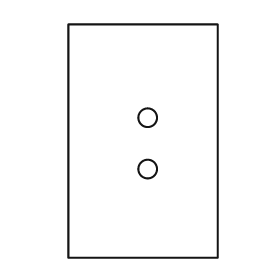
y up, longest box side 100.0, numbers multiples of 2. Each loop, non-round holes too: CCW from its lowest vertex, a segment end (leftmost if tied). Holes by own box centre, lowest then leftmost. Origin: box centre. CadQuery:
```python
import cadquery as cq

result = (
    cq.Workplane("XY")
    .moveTo(-32.0, -50.0)
    .lineTo(32.0, -50.0)
    .lineTo(32.0, 50.0)
    .lineTo(-32.0, 50.0)
    .close()
    .moveTo(2.0, -12.0)
    .circle(4.0)
    .moveTo(2.0, 10.0)
    .circle(4.0)
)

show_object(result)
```